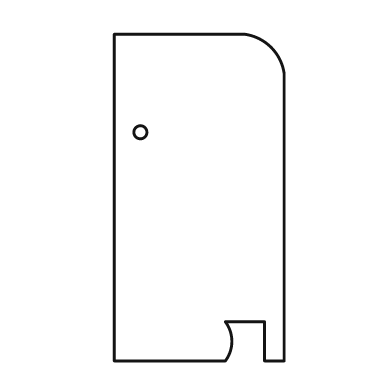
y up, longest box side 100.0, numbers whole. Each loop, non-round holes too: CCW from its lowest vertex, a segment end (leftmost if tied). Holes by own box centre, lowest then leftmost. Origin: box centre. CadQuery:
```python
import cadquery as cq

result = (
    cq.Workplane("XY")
    .moveTo(-26.0, -50.0)
    .lineTo(8.0, -50.0)
    .threePointArc((10.0, -44.0), (8.0, -38.0))
    .lineTo(20.0, -38.0)
    .lineTo(20.0, -50.0)
    .lineTo(26.0, -50.0)
    .lineTo(26.0, 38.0)
    .threePointArc((22.0, 46.0), (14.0, 50.0))
    .lineTo(-26.0, 50.0)
    .close()
    .moveTo(-18.0, 20.0)
    .circle(2.0)
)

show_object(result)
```